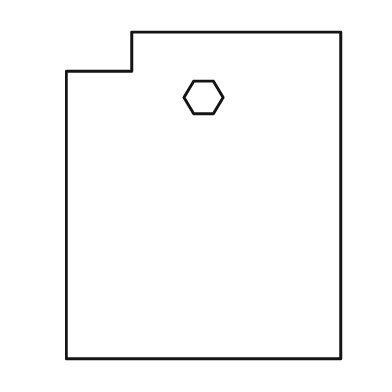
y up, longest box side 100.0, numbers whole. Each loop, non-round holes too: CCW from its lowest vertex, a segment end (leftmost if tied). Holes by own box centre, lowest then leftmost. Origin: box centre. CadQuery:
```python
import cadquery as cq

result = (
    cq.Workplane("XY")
    .moveTo(-42.0, -50.0)
    .lineTo(42.0, -50.0)
    .lineTo(42.0, 50.0)
    .lineTo(-22.0, 50.0)
    .lineTo(-22.0, 38.0)
    .lineTo(-42.0, 38.0)
    .close()
    .moveTo(-3.0, 25.0)
    .lineTo(3.0, 25.0)
    .lineTo(6.0, 30.0)
    .lineTo(3.0, 35.0)
    .lineTo(-3.0, 35.0)
    .lineTo(-6.0, 30.0)
    .close()
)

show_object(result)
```